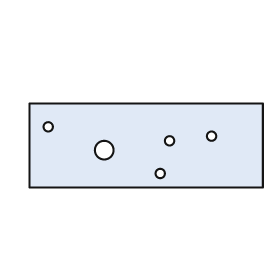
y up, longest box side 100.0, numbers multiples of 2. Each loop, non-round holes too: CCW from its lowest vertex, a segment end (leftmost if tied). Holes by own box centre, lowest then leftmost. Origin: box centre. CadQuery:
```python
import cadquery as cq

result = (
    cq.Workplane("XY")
    .moveTo(-50.0, -18.0)
    .lineTo(50.0, -18.0)
    .lineTo(50.0, 18.0)
    .lineTo(-50.0, 18.0)
    .close()
    .moveTo(6.0, -12.0)
    .circle(2.0)
    .moveTo(-18.0, -2.0)
    .circle(4.0)
    .moveTo(10.0, 2.0)
    .circle(2.0)
    .moveTo(28.0, 4.0)
    .circle(2.0)
    .moveTo(-42.0, 8.0)
    .circle(2.0)
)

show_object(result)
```